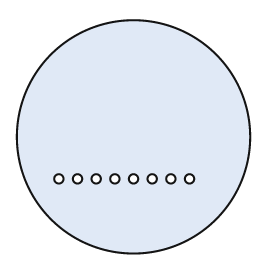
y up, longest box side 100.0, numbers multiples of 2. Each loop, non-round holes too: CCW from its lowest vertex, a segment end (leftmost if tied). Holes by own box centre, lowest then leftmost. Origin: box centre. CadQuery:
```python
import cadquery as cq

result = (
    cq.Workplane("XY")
    .moveTo(0.0, 0.0)
    .circle(50.0)
    .moveTo(-32.0, -18.0)
    .circle(2.0)
    .moveTo(-24.0, -18.0)
    .circle(2.0)
    .moveTo(-16.0, -18.0)
    .circle(2.0)
    .moveTo(-8.0, -18.0)
    .circle(2.0)
    .moveTo(0.0, -18.0)
    .circle(2.0)
    .moveTo(8.0, -18.0)
    .circle(2.0)
    .moveTo(16.0, -18.0)
    .circle(2.0)
    .moveTo(24.0, -18.0)
    .circle(2.0)
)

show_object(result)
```